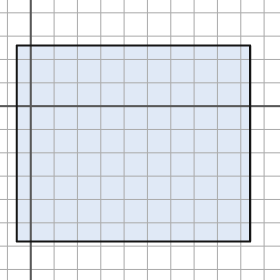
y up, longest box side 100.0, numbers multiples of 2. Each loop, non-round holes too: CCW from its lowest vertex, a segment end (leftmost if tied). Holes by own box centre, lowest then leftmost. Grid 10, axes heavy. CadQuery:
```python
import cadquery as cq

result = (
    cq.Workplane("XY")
    .moveTo(-6.0, -58.0)
    .lineTo(94.0, -58.0)
    .lineTo(94.0, 26.0)
    .lineTo(-6.0, 26.0)
    .close()
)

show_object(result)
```